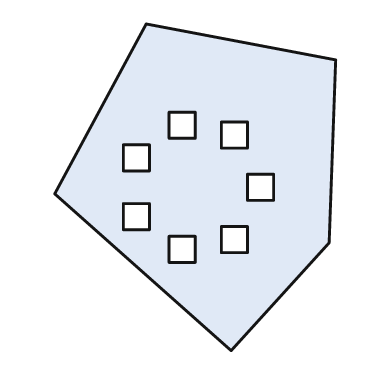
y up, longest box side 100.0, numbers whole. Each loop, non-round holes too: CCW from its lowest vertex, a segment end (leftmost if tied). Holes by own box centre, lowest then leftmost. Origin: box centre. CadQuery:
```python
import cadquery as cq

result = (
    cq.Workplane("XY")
    .moveTo(11.0, -50.0)
    .lineTo(41.0, -17.0)
    .lineTo(43.0, 39.0)
    .lineTo(-15.0, 50.0)
    .lineTo(-43.0, -2.0)
    .close()
    .moveTo(-8.0, -23.0)
    .lineTo(0.0, -23.0)
    .lineTo(0.0, -15.0)
    .lineTo(-8.0, -15.0)
    .close()
    .moveTo(8.0, -20.0)
    .lineTo(16.0, -20.0)
    .lineTo(16.0, -12.0)
    .lineTo(8.0, -12.0)
    .close()
    .moveTo(-22.0, -13.0)
    .lineTo(-14.0, -13.0)
    .lineTo(-14.0, -5.0)
    .lineTo(-22.0, -5.0)
    .close()
    .moveTo(16.0, -4.0)
    .lineTo(24.0, -4.0)
    .lineTo(24.0, 4.0)
    .lineTo(16.0, 4.0)
    .close()
    .moveTo(-22.0, 5.0)
    .lineTo(-14.0, 5.0)
    .lineTo(-14.0, 13.0)
    .lineTo(-22.0, 13.0)
    .close()
    .moveTo(8.0, 12.0)
    .lineTo(16.0, 12.0)
    .lineTo(16.0, 20.0)
    .lineTo(8.0, 20.0)
    .close()
    .moveTo(-8.0, 15.0)
    .lineTo(0.0, 15.0)
    .lineTo(0.0, 23.0)
    .lineTo(-8.0, 23.0)
    .close()
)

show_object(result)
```